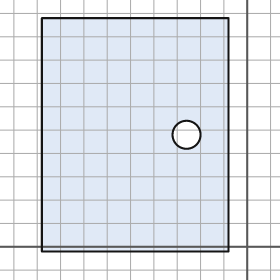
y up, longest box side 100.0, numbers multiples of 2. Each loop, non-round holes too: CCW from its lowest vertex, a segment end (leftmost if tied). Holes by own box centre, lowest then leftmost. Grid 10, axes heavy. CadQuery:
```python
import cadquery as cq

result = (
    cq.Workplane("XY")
    .moveTo(-88.0, -2.0)
    .lineTo(-8.0, -2.0)
    .lineTo(-8.0, 98.0)
    .lineTo(-88.0, 98.0)
    .close()
    .moveTo(-26.0, 48.0)
    .circle(6.0)
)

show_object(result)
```